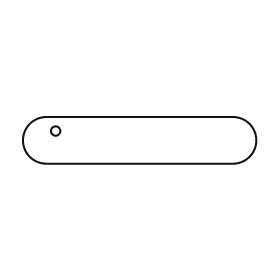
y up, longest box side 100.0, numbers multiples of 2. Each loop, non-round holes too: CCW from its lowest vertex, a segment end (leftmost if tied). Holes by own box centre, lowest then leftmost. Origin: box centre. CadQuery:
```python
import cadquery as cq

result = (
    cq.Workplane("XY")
    .moveTo(-40.0, -10.0)
    .lineTo(40.0, -10.0)
    .threePointArc((50.0, 0.0), (40.0, 10.0))
    .lineTo(-40.0, 10.0)
    .threePointArc((-50.0, 0.0), (-40.0, -10.0))
    .close()
    .moveTo(-36.0, 4.0)
    .circle(2.0)
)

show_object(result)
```